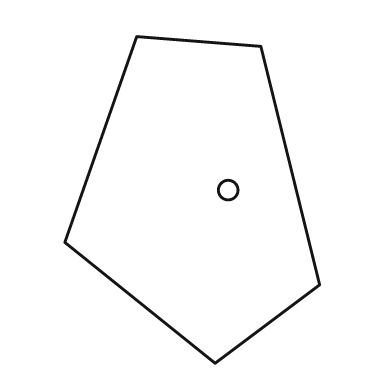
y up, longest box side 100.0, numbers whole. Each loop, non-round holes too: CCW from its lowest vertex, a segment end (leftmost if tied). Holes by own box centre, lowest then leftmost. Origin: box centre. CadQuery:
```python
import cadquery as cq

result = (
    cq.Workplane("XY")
    .moveTo(7.0, -50.0)
    .lineTo(39.0, -26.0)
    .lineTo(21.0, 47.0)
    .lineTo(-17.0, 50.0)
    .lineTo(-39.0, -13.0)
    .close()
    .moveTo(11.0, 3.0)
    .circle(3.0)
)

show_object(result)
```